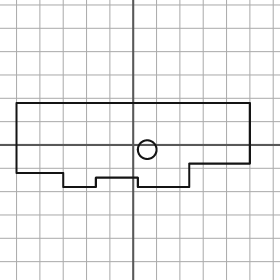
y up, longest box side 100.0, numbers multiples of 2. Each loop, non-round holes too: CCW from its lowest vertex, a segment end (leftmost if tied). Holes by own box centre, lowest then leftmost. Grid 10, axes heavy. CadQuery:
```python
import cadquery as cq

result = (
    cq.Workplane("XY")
    .moveTo(-30.0, -18.0)
    .lineTo(-16.0, -18.0)
    .lineTo(-16.0, -14.0)
    .lineTo(2.0, -14.0)
    .lineTo(2.0, -18.0)
    .lineTo(24.0, -18.0)
    .lineTo(24.0, -8.0)
    .lineTo(50.0, -8.0)
    .lineTo(50.0, 18.0)
    .lineTo(-50.0, 18.0)
    .lineTo(-50.0, -12.0)
    .lineTo(-30.0, -12.0)
    .close()
    .moveTo(6.0, -2.0)
    .circle(4.0)
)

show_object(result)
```